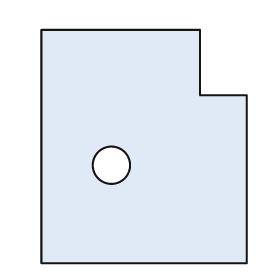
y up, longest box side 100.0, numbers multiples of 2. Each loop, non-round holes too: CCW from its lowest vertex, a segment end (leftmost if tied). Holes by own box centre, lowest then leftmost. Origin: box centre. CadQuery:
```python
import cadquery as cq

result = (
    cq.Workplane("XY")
    .moveTo(-44.0, -50.0)
    .lineTo(44.0, -50.0)
    .lineTo(44.0, 22.0)
    .lineTo(24.0, 22.0)
    .lineTo(24.0, 50.0)
    .lineTo(-44.0, 50.0)
    .close()
    .moveTo(-14.0, -8.0)
    .circle(8.0)
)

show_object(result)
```